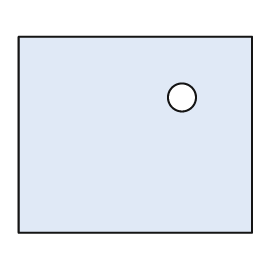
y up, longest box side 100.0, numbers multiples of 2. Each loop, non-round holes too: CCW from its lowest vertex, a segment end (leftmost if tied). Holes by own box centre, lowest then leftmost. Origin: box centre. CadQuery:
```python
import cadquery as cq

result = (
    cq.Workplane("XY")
    .moveTo(-50.0, -42.0)
    .lineTo(50.0, -42.0)
    .lineTo(50.0, 42.0)
    .lineTo(-50.0, 42.0)
    .close()
    .moveTo(20.0, 16.0)
    .circle(6.0)
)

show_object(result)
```